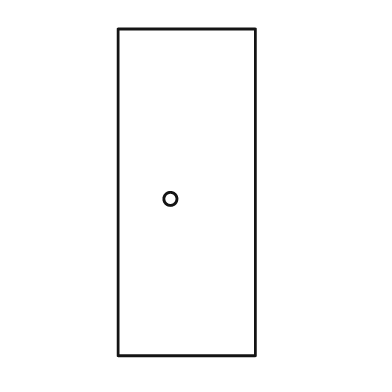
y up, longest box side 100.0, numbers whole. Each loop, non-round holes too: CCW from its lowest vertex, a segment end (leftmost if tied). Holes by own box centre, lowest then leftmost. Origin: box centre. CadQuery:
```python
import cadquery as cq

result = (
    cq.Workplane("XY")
    .moveTo(-21.0, -50.0)
    .lineTo(21.0, -50.0)
    .lineTo(21.0, 50.0)
    .lineTo(-21.0, 50.0)
    .close()
    .moveTo(-5.0, -2.0)
    .circle(2.0)
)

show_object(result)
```